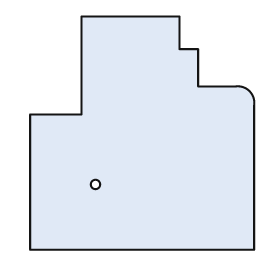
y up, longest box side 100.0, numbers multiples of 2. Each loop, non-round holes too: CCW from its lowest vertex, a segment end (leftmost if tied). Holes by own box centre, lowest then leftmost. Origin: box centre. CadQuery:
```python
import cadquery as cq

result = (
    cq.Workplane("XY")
    .moveTo(-48.0, -50.0)
    .lineTo(48.0, -50.0)
    .lineTo(48.0, 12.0)
    .threePointArc((46.0, 18.0), (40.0, 20.0))
    .lineTo(24.0, 20.0)
    .lineTo(24.0, 36.0)
    .lineTo(16.0, 36.0)
    .lineTo(16.0, 50.0)
    .lineTo(-26.0, 50.0)
    .lineTo(-26.0, 8.0)
    .lineTo(-48.0, 8.0)
    .close()
    .moveTo(-20.0, -22.0)
    .circle(2.0)
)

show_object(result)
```